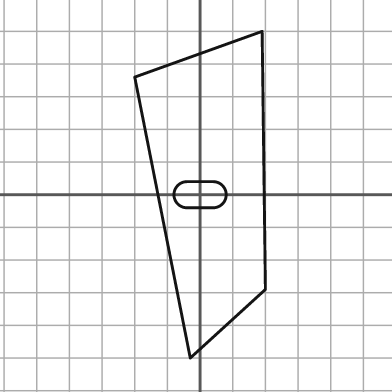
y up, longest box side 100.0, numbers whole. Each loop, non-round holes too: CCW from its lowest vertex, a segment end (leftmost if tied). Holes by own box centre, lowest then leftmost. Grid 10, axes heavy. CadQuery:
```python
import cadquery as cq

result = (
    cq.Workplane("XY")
    .moveTo(-3.0, -50.0)
    .lineTo(20.0, -29.0)
    .lineTo(19.0, 50.0)
    .lineTo(-20.0, 36.0)
    .close()
    .moveTo(-4.0, -4.0)
    .lineTo(4.0, -4.0)
    .threePointArc((8.0, 0.0), (4.0, 4.0))
    .lineTo(-4.0, 4.0)
    .threePointArc((-8.0, 0.0), (-4.0, -4.0))
    .close()
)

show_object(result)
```